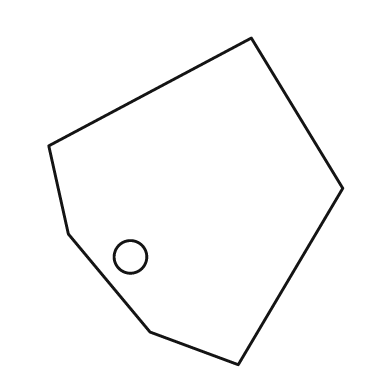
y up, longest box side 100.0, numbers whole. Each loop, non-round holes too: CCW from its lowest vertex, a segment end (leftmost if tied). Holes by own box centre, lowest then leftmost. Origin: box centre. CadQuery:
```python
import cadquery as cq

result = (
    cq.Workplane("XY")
    .moveTo(13.0, -50.0)
    .lineTo(45.0, 4.0)
    .lineTo(17.0, 50.0)
    .lineTo(-45.0, 17.0)
    .lineTo(-39.0, -10.0)
    .lineTo(-14.0, -40.0)
    .close()
    .moveTo(-20.0, -17.0)
    .circle(5.0)
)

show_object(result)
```